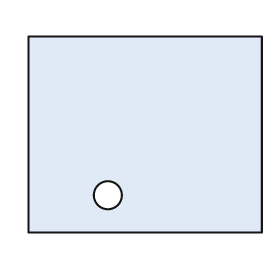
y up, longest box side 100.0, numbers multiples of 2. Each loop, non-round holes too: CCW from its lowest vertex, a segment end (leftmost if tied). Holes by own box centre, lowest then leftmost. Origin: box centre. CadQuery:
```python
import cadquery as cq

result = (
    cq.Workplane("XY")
    .moveTo(-50.0, -42.0)
    .lineTo(50.0, -42.0)
    .lineTo(50.0, 42.0)
    .lineTo(-50.0, 42.0)
    .close()
    .moveTo(-16.0, -26.0)
    .circle(6.0)
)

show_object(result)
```